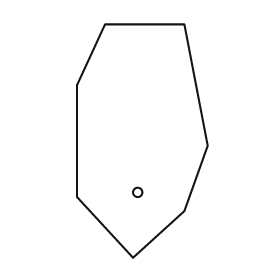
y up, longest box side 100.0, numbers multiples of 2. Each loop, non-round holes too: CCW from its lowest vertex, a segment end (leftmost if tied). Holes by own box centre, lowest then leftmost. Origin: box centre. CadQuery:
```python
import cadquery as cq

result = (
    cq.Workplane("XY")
    .moveTo(-4.0, -50.0)
    .lineTo(18.0, -30.0)
    .lineTo(28.0, -2.0)
    .lineTo(18.0, 50.0)
    .lineTo(-16.0, 50.0)
    .lineTo(-28.0, 24.0)
    .lineTo(-28.0, -24.0)
    .close()
    .moveTo(-2.0, -22.0)
    .circle(2.0)
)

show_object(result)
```